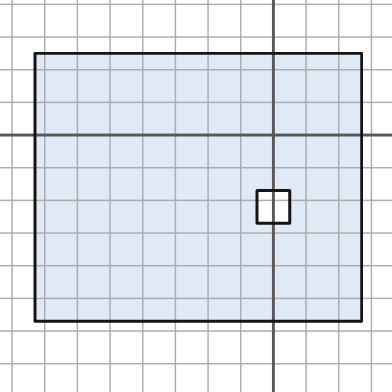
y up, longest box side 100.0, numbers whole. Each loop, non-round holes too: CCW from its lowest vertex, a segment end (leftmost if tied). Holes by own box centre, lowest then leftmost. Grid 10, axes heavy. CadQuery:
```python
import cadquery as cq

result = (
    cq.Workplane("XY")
    .moveTo(-73.0, -57.0)
    .lineTo(27.0, -57.0)
    .lineTo(27.0, 25.0)
    .lineTo(-73.0, 25.0)
    .close()
    .moveTo(-5.0, -27.0)
    .lineTo(5.0, -27.0)
    .lineTo(5.0, -17.0)
    .lineTo(-5.0, -17.0)
    .close()
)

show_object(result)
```